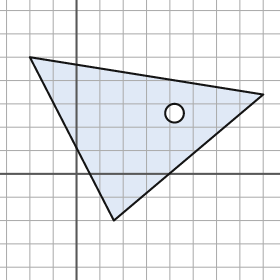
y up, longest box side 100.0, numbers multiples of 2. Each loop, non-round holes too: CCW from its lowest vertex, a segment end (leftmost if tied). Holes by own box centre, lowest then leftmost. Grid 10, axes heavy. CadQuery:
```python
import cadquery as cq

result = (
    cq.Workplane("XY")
    .moveTo(16.0, -20.0)
    .lineTo(80.0, 34.0)
    .lineTo(-20.0, 50.0)
    .close()
    .moveTo(42.0, 26.0)
    .circle(4.0)
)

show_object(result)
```